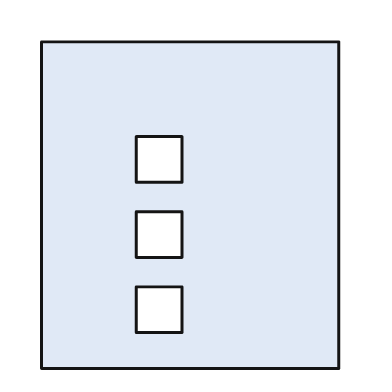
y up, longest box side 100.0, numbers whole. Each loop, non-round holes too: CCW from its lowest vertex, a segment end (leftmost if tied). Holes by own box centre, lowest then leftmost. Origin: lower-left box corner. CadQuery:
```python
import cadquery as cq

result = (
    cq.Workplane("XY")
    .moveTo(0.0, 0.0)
    .lineTo(91.0, 0.0)
    .lineTo(91.0, 100.0)
    .lineTo(0.0, 100.0)
    .close()
    .moveTo(29.0, 11.0)
    .lineTo(43.0, 11.0)
    .lineTo(43.0, 25.0)
    .lineTo(29.0, 25.0)
    .close()
    .moveTo(29.0, 34.0)
    .lineTo(43.0, 34.0)
    .lineTo(43.0, 48.0)
    .lineTo(29.0, 48.0)
    .close()
    .moveTo(29.0, 57.0)
    .lineTo(43.0, 57.0)
    .lineTo(43.0, 71.0)
    .lineTo(29.0, 71.0)
    .close()
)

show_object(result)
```